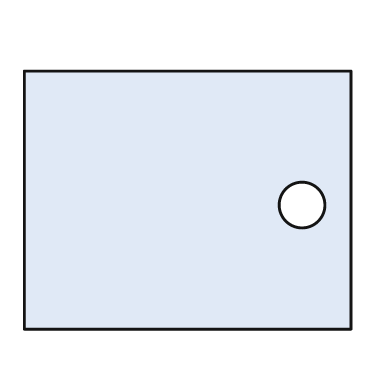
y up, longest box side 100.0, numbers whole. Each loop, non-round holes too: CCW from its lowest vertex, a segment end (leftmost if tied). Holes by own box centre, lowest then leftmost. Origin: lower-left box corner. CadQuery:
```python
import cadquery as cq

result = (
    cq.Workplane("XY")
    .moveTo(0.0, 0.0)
    .lineTo(100.0, 0.0)
    .lineTo(100.0, 79.0)
    .lineTo(0.0, 79.0)
    .close()
    .moveTo(85.0, 38.0)
    .circle(7.0)
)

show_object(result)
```